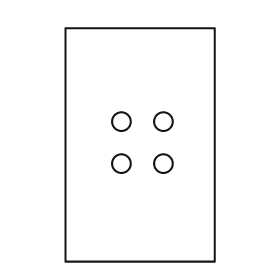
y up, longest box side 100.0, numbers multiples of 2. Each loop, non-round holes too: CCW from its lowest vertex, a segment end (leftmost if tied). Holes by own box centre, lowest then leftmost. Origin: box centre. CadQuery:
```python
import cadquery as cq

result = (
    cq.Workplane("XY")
    .moveTo(-32.0, -50.0)
    .lineTo(32.0, -50.0)
    .lineTo(32.0, 50.0)
    .lineTo(-32.0, 50.0)
    .close()
    .moveTo(-8.0, -8.0)
    .circle(4.0)
    .moveTo(10.0, -8.0)
    .circle(4.0)
    .moveTo(-8.0, 10.0)
    .circle(4.0)
    .moveTo(10.0, 10.0)
    .circle(4.0)
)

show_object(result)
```